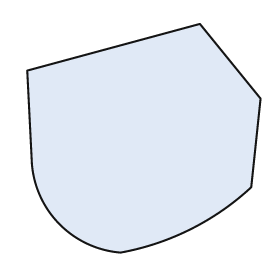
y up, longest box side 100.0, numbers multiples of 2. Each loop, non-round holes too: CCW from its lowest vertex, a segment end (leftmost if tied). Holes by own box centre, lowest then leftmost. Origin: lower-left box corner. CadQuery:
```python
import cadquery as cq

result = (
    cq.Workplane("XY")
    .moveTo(40.0, 0.0)
    .threePointArc((70.0, 10.0), (96.0, 28.0))
    .lineTo(100.0, 66.0)
    .lineTo(74.0, 98.0)
    .lineTo(0.0, 78.0)
    .lineTo(2.0, 38.0)
    .threePointArc((14.0, 12.0), (40.0, 0.0))
    .close()
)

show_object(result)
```